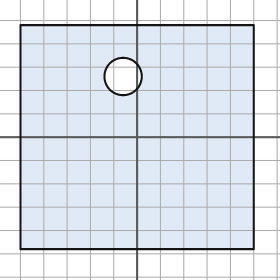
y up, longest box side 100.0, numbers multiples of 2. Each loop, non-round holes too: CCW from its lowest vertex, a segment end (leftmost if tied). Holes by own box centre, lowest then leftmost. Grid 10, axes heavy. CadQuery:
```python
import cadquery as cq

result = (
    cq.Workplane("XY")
    .moveTo(-50.0, -48.0)
    .lineTo(50.0, -48.0)
    .lineTo(50.0, 48.0)
    .lineTo(-50.0, 48.0)
    .close()
    .moveTo(-6.0, 26.0)
    .circle(8.0)
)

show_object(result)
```